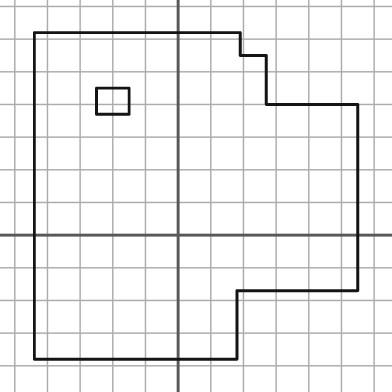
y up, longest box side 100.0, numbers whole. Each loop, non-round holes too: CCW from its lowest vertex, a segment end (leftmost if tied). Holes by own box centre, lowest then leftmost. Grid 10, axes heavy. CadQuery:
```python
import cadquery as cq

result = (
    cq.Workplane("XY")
    .moveTo(-44.0, -38.0)
    .lineTo(18.0, -38.0)
    .lineTo(18.0, -17.0)
    .lineTo(55.0, -17.0)
    .lineTo(55.0, 40.0)
    .lineTo(27.0, 40.0)
    .lineTo(27.0, 55.0)
    .lineTo(19.0, 55.0)
    .lineTo(19.0, 62.0)
    .lineTo(-44.0, 62.0)
    .close()
    .moveTo(-25.0, 37.0)
    .lineTo(-15.0, 37.0)
    .lineTo(-15.0, 45.0)
    .lineTo(-25.0, 45.0)
    .close()
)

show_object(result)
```